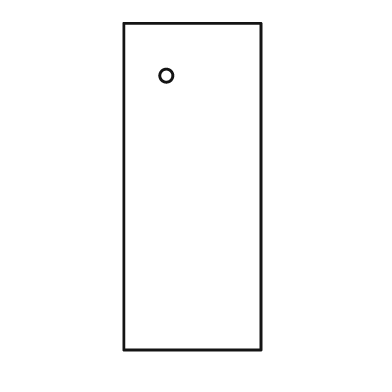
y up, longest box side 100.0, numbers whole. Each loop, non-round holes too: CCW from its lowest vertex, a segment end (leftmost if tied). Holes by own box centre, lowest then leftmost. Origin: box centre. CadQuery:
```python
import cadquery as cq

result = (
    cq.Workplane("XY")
    .moveTo(-21.0, -50.0)
    .lineTo(21.0, -50.0)
    .lineTo(21.0, 50.0)
    .lineTo(-21.0, 50.0)
    .close()
    .moveTo(-8.0, 34.0)
    .circle(2.0)
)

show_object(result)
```